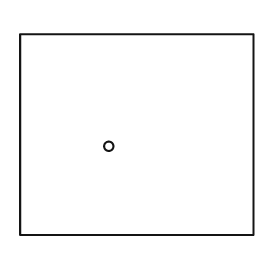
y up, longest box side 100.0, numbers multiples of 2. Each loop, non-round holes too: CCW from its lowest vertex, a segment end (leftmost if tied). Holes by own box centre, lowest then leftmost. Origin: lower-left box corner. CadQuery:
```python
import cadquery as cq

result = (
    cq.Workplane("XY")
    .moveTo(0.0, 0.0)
    .lineTo(100.0, 0.0)
    .lineTo(100.0, 86.0)
    .lineTo(0.0, 86.0)
    .close()
    .moveTo(38.0, 38.0)
    .circle(2.0)
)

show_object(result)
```